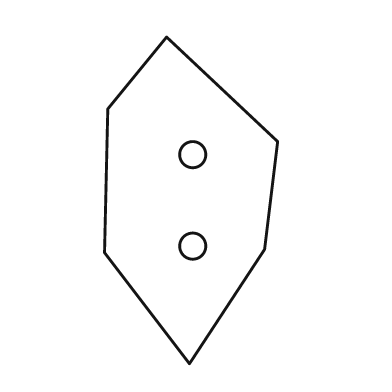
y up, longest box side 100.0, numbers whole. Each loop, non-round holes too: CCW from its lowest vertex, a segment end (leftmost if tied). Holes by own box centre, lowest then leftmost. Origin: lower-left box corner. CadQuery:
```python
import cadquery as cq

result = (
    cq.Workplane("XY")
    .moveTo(26.0, 0.0)
    .lineTo(49.0, 35.0)
    .lineTo(53.0, 68.0)
    .lineTo(19.0, 100.0)
    .lineTo(1.0, 78.0)
    .lineTo(0.0, 34.0)
    .close()
    .moveTo(27.0, 36.0)
    .circle(4.0)
    .moveTo(27.0, 64.0)
    .circle(4.0)
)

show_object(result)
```